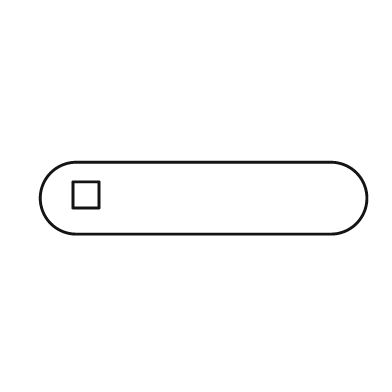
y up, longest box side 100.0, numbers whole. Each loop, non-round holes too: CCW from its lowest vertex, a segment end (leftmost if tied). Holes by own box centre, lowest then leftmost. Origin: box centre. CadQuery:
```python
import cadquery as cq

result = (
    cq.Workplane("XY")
    .moveTo(-39.0, -11.0)
    .lineTo(39.0, -11.0)
    .threePointArc((50.0, 0.0), (39.0, 11.0))
    .lineTo(-39.0, 11.0)
    .threePointArc((-50.0, 0.0), (-39.0, -11.0))
    .close()
    .moveTo(-40.0, -3.0)
    .lineTo(-32.0, -3.0)
    .lineTo(-32.0, 5.0)
    .lineTo(-40.0, 5.0)
    .close()
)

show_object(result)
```